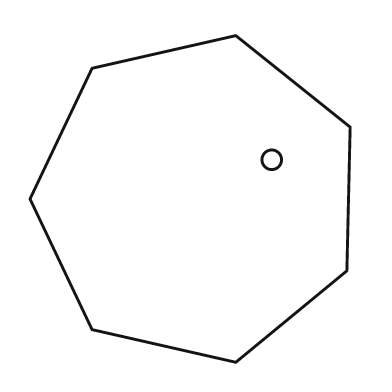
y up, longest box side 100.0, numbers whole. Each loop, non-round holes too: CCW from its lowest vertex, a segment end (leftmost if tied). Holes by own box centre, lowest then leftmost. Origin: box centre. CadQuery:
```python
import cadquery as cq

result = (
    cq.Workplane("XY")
    .moveTo(14.0, -50.0)
    .lineTo(48.0, -22.0)
    .lineTo(49.0, 22.0)
    .lineTo(14.0, 50.0)
    .lineTo(-30.0, 40.0)
    .lineTo(-49.0, 0.0)
    .lineTo(-30.0, -40.0)
    .close()
    .moveTo(25.0, 12.0)
    .circle(3.0)
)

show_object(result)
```